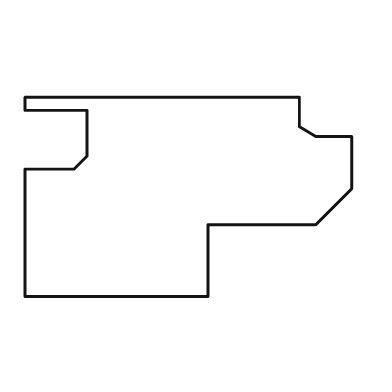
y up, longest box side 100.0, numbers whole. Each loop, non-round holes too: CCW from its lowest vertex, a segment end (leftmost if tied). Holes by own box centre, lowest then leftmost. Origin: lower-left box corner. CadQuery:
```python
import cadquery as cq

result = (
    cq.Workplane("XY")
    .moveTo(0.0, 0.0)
    .lineTo(56.0, 0.0)
    .lineTo(56.0, 22.0)
    .lineTo(89.0, 22.0)
    .lineTo(100.0, 33.0)
    .lineTo(100.0, 49.0)
    .lineTo(89.0, 49.0)
    .lineTo(84.0, 52.0)
    .lineTo(84.0, 61.0)
    .lineTo(0.0, 61.0)
    .lineTo(0.0, 57.0)
    .lineTo(19.0, 57.0)
    .lineTo(19.0, 43.0)
    .lineTo(15.0, 39.0)
    .lineTo(0.0, 39.0)
    .close()
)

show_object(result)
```